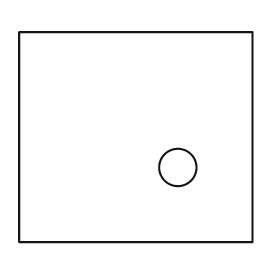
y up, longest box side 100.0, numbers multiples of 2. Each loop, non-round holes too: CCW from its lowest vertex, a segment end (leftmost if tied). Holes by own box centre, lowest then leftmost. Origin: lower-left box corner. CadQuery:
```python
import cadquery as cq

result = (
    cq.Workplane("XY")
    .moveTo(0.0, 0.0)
    .lineTo(100.0, 0.0)
    .lineTo(100.0, 90.0)
    .lineTo(0.0, 90.0)
    .close()
    .moveTo(68.0, 32.0)
    .circle(8.0)
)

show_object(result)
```